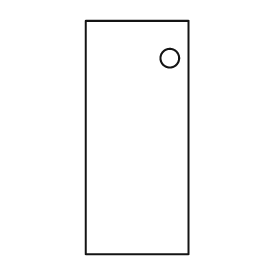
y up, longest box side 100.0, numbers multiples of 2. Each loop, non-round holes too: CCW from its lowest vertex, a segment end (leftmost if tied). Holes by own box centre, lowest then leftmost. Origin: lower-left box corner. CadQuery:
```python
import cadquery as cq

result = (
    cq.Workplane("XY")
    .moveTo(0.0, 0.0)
    .lineTo(44.0, 0.0)
    .lineTo(44.0, 100.0)
    .lineTo(0.0, 100.0)
    .close()
    .moveTo(36.0, 84.0)
    .circle(4.0)
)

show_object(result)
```